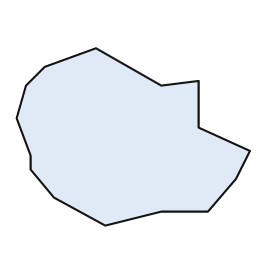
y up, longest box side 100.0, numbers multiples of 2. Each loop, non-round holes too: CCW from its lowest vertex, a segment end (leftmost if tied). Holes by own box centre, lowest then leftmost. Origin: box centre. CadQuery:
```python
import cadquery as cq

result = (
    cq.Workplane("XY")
    .moveTo(-12.0, -38.0)
    .lineTo(12.0, -32.0)
    .lineTo(32.0, -32.0)
    .lineTo(44.0, -18.0)
    .lineTo(50.0, -6.0)
    .lineTo(28.0, 4.0)
    .lineTo(28.0, 24.0)
    .lineTo(12.0, 22.0)
    .lineTo(-16.0, 38.0)
    .lineTo(-38.0, 30.0)
    .lineTo(-46.0, 22.0)
    .lineTo(-50.0, 8.0)
    .lineTo(-44.0, -8.0)
    .lineTo(-44.0, -14.0)
    .lineTo(-34.0, -26.0)
    .close()
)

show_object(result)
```